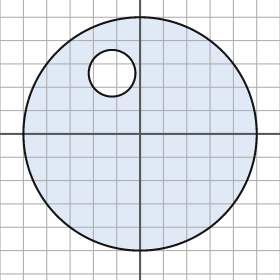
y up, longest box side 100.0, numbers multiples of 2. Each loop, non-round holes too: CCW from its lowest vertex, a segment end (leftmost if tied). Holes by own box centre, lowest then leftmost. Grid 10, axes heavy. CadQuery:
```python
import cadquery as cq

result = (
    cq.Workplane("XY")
    .moveTo(0.0, 0.0)
    .circle(50.0)
    .moveTo(-12.0, 26.0)
    .circle(10.0)
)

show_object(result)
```